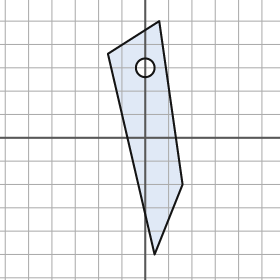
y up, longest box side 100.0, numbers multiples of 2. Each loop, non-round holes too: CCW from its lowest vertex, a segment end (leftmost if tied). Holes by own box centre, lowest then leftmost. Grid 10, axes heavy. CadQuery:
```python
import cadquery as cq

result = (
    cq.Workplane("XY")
    .moveTo(4.0, -50.0)
    .lineTo(16.0, -20.0)
    .lineTo(6.0, 50.0)
    .lineTo(-16.0, 36.0)
    .close()
    .moveTo(0.0, 30.0)
    .circle(4.0)
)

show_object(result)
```